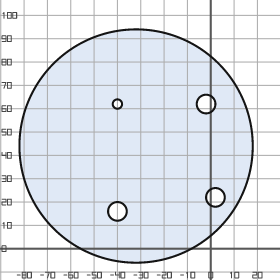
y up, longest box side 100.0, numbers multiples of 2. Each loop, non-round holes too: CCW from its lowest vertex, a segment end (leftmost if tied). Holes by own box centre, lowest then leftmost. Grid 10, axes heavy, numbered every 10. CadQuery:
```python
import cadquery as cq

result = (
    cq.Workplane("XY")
    .moveTo(-32.0, 44.0)
    .circle(50.0)
    .moveTo(-40.0, 16.0)
    .circle(4.0)
    .moveTo(2.0, 22.0)
    .circle(4.0)
    .moveTo(-40.0, 62.0)
    .circle(2.0)
    .moveTo(-2.0, 62.0)
    .circle(4.0)
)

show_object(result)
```